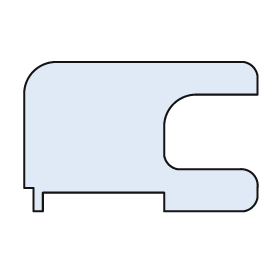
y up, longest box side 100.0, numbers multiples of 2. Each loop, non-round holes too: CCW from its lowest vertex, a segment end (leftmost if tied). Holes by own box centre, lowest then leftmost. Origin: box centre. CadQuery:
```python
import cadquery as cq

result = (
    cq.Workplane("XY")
    .moveTo(-46.0, -32.0)
    .lineTo(-42.0, -32.0)
    .lineTo(-42.0, -24.0)
    .lineTo(10.0, -24.0)
    .lineTo(10.0, -32.0)
    .lineTo(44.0, -32.0)
    .threePointArc((48.0, -30.0), (50.0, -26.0))
    .lineTo(50.0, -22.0)
    .threePointArc((48.0, -16.0), (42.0, -14.0))
    .lineTo(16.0, -14.0)
    .threePointArc((12.0, -12.0), (10.0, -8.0))
    .lineTo(10.0, 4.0)
    .threePointArc((14.0, 14.0), (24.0, 18.0))
    .lineTo(50.0, 18.0)
    .lineTo(50.0, 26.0)
    .threePointArc((48.0, 30.0), (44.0, 32.0))
    .lineTo(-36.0, 32.0)
    .threePointArc((-46.0, 28.0), (-50.0, 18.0))
    .lineTo(-50.0, -22.0)
    .lineTo(-46.0, -22.0)
    .close()
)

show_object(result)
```